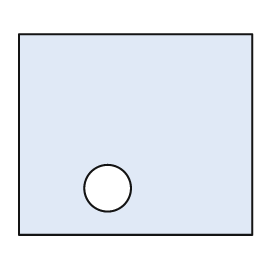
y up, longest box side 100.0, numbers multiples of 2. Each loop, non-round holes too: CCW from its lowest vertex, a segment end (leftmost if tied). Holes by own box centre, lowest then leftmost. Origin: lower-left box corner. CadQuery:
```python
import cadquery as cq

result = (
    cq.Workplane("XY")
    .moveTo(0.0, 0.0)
    .lineTo(100.0, 0.0)
    .lineTo(100.0, 86.0)
    .lineTo(0.0, 86.0)
    .close()
    .moveTo(38.0, 20.0)
    .circle(10.0)
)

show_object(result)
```